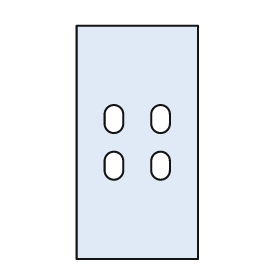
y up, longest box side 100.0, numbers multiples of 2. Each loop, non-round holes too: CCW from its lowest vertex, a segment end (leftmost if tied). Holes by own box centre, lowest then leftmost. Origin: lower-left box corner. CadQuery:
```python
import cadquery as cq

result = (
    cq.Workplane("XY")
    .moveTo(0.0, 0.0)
    .lineTo(52.0, 0.0)
    .lineTo(52.0, 100.0)
    .lineTo(0.0, 100.0)
    .close()
    .moveTo(12.0, 38.0)
    .threePointArc((16.0, 34.0), (20.0, 38.0))
    .lineTo(20.0, 42.0)
    .threePointArc((16.0, 46.0), (12.0, 42.0))
    .close()
    .moveTo(32.0, 38.0)
    .threePointArc((36.0, 34.0), (40.0, 38.0))
    .lineTo(40.0, 42.0)
    .threePointArc((36.0, 46.0), (32.0, 42.0))
    .close()
    .moveTo(12.0, 58.0)
    .threePointArc((16.0, 54.0), (20.0, 58.0))
    .lineTo(20.0, 62.0)
    .threePointArc((16.0, 66.0), (12.0, 62.0))
    .close()
    .moveTo(32.0, 58.0)
    .threePointArc((36.0, 54.0), (40.0, 58.0))
    .lineTo(40.0, 62.0)
    .threePointArc((36.0, 66.0), (32.0, 62.0))
    .close()
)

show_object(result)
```